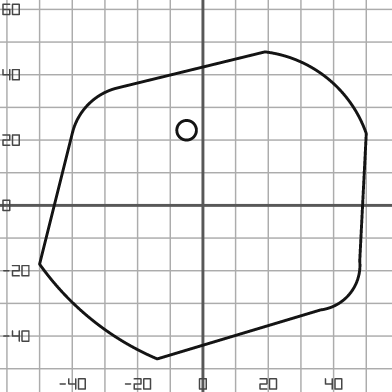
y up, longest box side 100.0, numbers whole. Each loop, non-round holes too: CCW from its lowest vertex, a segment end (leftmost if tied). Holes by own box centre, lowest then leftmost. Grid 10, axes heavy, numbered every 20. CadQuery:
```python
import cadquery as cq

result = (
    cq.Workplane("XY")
    .moveTo(-14.0, -47.0)
    .lineTo(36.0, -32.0)
    .threePointArc((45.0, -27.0), (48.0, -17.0))
    .lineTo(50.0, 22.0)
    .threePointArc((38.0, 39.0), (19.0, 47.0))
    .lineTo(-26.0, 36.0)
    .threePointArc((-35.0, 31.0), (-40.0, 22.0))
    .lineTo(-50.0, -18.0)
    .threePointArc((-34.0, -35.0), (-14.0, -47.0))
    .close()
    .moveTo(-5.0, 23.0)
    .circle(3.0)
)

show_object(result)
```